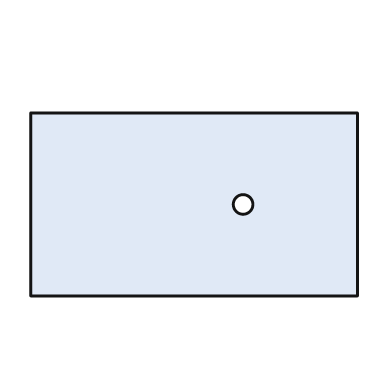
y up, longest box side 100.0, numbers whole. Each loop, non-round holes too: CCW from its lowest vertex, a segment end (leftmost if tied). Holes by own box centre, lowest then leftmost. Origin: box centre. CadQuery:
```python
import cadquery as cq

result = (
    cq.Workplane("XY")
    .moveTo(-50.0, -28.0)
    .lineTo(50.0, -28.0)
    .lineTo(50.0, 28.0)
    .lineTo(-50.0, 28.0)
    .close()
    .moveTo(15.0, 0.0)
    .circle(3.0)
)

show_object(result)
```